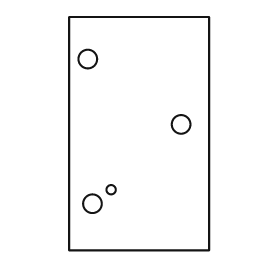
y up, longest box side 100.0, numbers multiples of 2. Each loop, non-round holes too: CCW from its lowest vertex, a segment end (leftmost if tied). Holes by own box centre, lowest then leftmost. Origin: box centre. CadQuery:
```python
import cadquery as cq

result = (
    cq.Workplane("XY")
    .moveTo(-30.0, -50.0)
    .lineTo(30.0, -50.0)
    .lineTo(30.0, 50.0)
    .lineTo(-30.0, 50.0)
    .close()
    .moveTo(-20.0, -30.0)
    .circle(4.0)
    .moveTo(-12.0, -24.0)
    .circle(2.0)
    .moveTo(18.0, 4.0)
    .circle(4.0)
    .moveTo(-22.0, 32.0)
    .circle(4.0)
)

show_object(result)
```